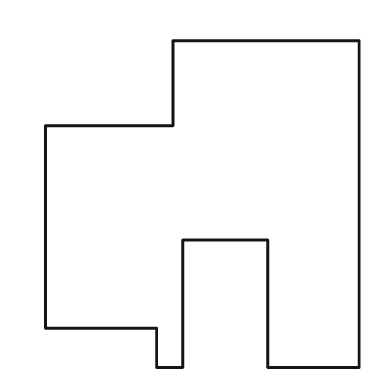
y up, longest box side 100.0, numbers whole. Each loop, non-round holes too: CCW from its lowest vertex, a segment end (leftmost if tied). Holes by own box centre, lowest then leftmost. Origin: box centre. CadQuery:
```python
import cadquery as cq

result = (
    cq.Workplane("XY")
    .moveTo(-14.0, -50.0)
    .lineTo(-6.0, -50.0)
    .lineTo(-6.0, -11.0)
    .lineTo(20.0, -11.0)
    .lineTo(20.0, -50.0)
    .lineTo(48.0, -50.0)
    .lineTo(48.0, 50.0)
    .lineTo(-9.0, 50.0)
    .lineTo(-9.0, 24.0)
    .lineTo(-48.0, 24.0)
    .lineTo(-48.0, -38.0)
    .lineTo(-14.0, -38.0)
    .close()
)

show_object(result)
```